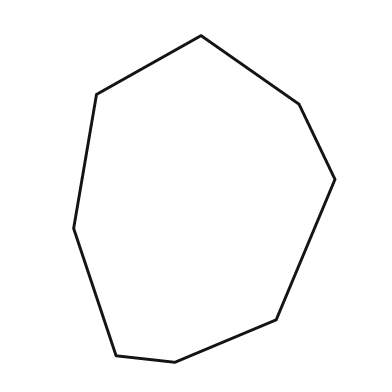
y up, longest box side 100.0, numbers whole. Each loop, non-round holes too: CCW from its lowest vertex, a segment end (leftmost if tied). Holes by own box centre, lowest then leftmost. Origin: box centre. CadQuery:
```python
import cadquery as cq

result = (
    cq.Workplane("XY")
    .moveTo(-9.0, -50.0)
    .lineTo(22.0, -37.0)
    .lineTo(40.0, 6.0)
    .lineTo(29.0, 29.0)
    .lineTo(-1.0, 50.0)
    .lineTo(-33.0, 32.0)
    .lineTo(-40.0, -9.0)
    .lineTo(-27.0, -48.0)
    .close()
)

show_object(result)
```